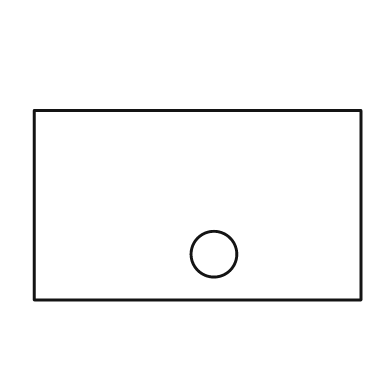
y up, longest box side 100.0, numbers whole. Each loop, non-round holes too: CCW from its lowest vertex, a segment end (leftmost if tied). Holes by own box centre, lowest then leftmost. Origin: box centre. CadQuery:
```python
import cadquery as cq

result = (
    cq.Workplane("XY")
    .moveTo(-50.0, -29.0)
    .lineTo(50.0, -29.0)
    .lineTo(50.0, 29.0)
    .lineTo(-50.0, 29.0)
    .close()
    .moveTo(5.0, -15.0)
    .circle(7.0)
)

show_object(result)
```